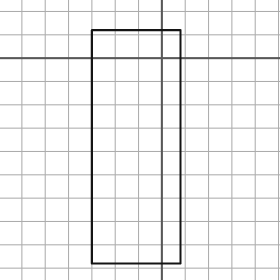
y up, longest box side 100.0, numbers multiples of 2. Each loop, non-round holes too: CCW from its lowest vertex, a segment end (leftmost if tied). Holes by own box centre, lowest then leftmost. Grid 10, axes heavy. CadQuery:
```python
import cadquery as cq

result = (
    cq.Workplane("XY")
    .moveTo(-30.0, -88.0)
    .lineTo(8.0, -88.0)
    .lineTo(8.0, 12.0)
    .lineTo(-30.0, 12.0)
    .close()
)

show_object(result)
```